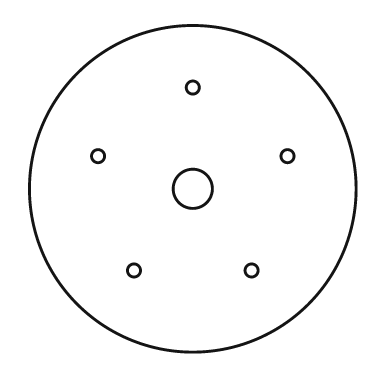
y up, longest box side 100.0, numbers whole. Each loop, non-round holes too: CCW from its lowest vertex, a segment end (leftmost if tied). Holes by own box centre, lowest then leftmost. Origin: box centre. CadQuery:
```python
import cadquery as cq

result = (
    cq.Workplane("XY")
    .moveTo(0.0, 0.0)
    .circle(50.0)
    .moveTo(-18.0, -25.0)
    .circle(2.0)
    .moveTo(18.0, -25.0)
    .circle(2.0)
    .moveTo(0.0, 0.0)
    .circle(6.0)
    .moveTo(-29.0, 10.0)
    .circle(2.0)
    .moveTo(29.0, 10.0)
    .circle(2.0)
    .moveTo(0.0, 31.0)
    .circle(2.0)
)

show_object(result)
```